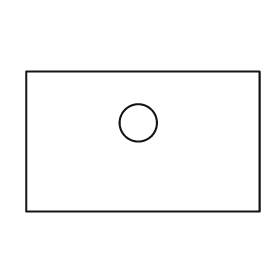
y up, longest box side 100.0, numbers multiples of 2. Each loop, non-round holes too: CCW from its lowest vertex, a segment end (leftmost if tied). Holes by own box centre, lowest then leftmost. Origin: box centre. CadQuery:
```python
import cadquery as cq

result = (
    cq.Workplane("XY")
    .moveTo(-50.0, -30.0)
    .lineTo(50.0, -30.0)
    .lineTo(50.0, 30.0)
    .lineTo(-50.0, 30.0)
    .close()
    .moveTo(-2.0, 8.0)
    .circle(8.0)
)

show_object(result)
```